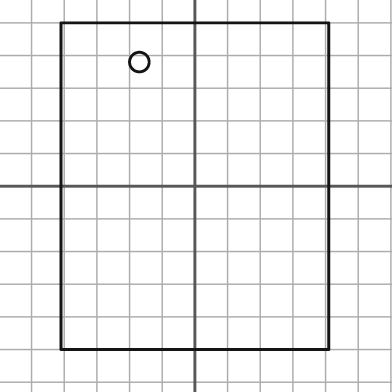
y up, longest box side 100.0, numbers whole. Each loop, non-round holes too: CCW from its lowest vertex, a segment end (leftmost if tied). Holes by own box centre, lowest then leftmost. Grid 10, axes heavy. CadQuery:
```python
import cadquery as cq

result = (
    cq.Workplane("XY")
    .moveTo(-41.0, -50.0)
    .lineTo(41.0, -50.0)
    .lineTo(41.0, 50.0)
    .lineTo(-41.0, 50.0)
    .close()
    .moveTo(-17.0, 38.0)
    .circle(3.0)
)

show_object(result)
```